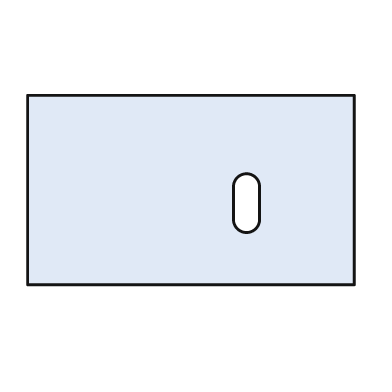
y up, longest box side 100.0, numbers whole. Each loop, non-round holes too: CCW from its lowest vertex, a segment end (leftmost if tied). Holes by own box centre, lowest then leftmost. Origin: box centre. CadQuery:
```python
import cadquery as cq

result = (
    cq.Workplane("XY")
    .moveTo(-50.0, -29.0)
    .lineTo(50.0, -29.0)
    .lineTo(50.0, 29.0)
    .lineTo(-50.0, 29.0)
    .close()
    .moveTo(13.0, -9.0)
    .threePointArc((17.0, -13.0), (21.0, -9.0))
    .lineTo(21.0, 1.0)
    .threePointArc((17.0, 5.0), (13.0, 1.0))
    .close()
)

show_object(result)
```